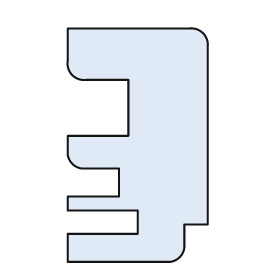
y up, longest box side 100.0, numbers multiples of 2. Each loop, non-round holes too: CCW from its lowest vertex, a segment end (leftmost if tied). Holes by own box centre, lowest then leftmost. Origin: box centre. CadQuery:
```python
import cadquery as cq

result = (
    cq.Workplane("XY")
    .moveTo(-30.0, -50.0)
    .lineTo(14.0, -50.0)
    .threePointArc((18.0, -48.0), (20.0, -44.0))
    .lineTo(20.0, -34.0)
    .lineTo(30.0, -34.0)
    .lineTo(30.0, 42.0)
    .threePointArc((28.0, 48.0), (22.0, 50.0))
    .lineTo(-30.0, 50.0)
    .lineTo(-30.0, 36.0)
    .threePointArc((-28.0, 30.0), (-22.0, 28.0))
    .lineTo(-4.0, 28.0)
    .lineTo(-4.0, 4.0)
    .lineTo(-30.0, 4.0)
    .lineTo(-30.0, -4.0)
    .threePointArc((-28.0, -8.0), (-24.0, -10.0))
    .lineTo(-8.0, -10.0)
    .lineTo(-8.0, -22.0)
    .lineTo(-30.0, -22.0)
    .lineTo(-30.0, -28.0)
    .lineTo(0.0, -28.0)
    .lineTo(0.0, -38.0)
    .lineTo(-30.0, -38.0)
    .close()
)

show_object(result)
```